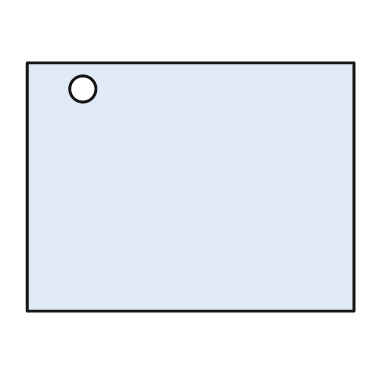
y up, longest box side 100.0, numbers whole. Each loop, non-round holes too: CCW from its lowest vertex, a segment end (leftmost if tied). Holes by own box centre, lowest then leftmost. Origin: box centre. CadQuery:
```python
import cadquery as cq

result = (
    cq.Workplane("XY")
    .moveTo(-50.0, -38.0)
    .lineTo(50.0, -38.0)
    .lineTo(50.0, 38.0)
    .lineTo(-50.0, 38.0)
    .close()
    .moveTo(-33.0, 30.0)
    .circle(4.0)
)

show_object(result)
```